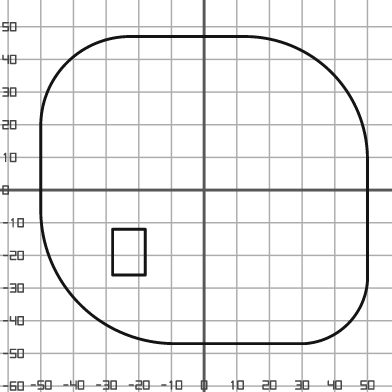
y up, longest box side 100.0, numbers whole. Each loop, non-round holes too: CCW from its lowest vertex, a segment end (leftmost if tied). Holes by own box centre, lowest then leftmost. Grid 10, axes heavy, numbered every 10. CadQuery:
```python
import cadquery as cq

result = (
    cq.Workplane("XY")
    .moveTo(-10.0, -47.0)
    .lineTo(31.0, -47.0)
    .threePointArc((44.0, -41.0), (50.0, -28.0))
    .lineTo(50.0, 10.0)
    .threePointArc((39.0, 36.0), (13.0, 47.0))
    .lineTo(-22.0, 47.0)
    .threePointArc((-42.0, 39.0), (-50.0, 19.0))
    .lineTo(-50.0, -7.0)
    .threePointArc((-38.0, -35.0), (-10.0, -47.0))
    .close()
    .moveTo(-28.0, -26.0)
    .lineTo(-18.0, -26.0)
    .lineTo(-18.0, -12.0)
    .lineTo(-28.0, -12.0)
    .close()
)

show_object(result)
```